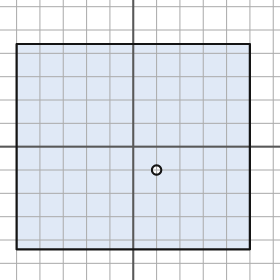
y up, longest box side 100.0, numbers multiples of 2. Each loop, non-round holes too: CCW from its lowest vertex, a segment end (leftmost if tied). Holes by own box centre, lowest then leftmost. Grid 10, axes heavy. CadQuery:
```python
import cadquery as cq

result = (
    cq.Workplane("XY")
    .moveTo(-50.0, -44.0)
    .lineTo(50.0, -44.0)
    .lineTo(50.0, 44.0)
    .lineTo(-50.0, 44.0)
    .close()
    .moveTo(10.0, -10.0)
    .circle(2.0)
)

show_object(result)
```